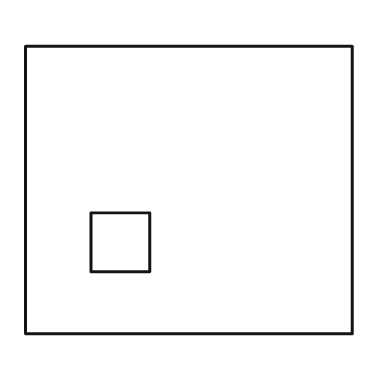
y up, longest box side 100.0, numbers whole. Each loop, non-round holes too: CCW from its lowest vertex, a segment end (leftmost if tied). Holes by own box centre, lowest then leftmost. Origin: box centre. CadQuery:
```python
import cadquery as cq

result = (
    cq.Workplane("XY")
    .moveTo(-50.0, -44.0)
    .lineTo(50.0, -44.0)
    .lineTo(50.0, 44.0)
    .lineTo(-50.0, 44.0)
    .close()
    .moveTo(-30.0, -25.0)
    .lineTo(-12.0, -25.0)
    .lineTo(-12.0, -7.0)
    .lineTo(-30.0, -7.0)
    .close()
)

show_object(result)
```